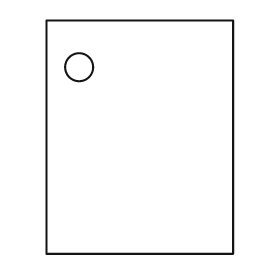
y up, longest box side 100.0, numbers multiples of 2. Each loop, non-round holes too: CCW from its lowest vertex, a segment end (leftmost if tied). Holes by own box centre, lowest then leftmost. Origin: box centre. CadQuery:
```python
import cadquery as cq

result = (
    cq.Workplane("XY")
    .moveTo(-40.0, -50.0)
    .lineTo(40.0, -50.0)
    .lineTo(40.0, 50.0)
    .lineTo(-40.0, 50.0)
    .close()
    .moveTo(-26.0, 30.0)
    .circle(6.0)
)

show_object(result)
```